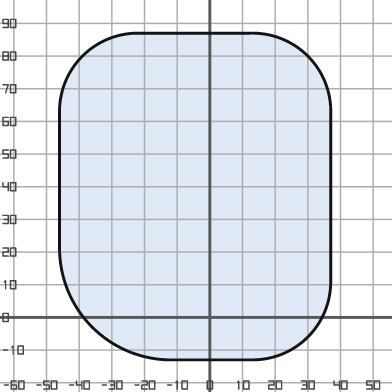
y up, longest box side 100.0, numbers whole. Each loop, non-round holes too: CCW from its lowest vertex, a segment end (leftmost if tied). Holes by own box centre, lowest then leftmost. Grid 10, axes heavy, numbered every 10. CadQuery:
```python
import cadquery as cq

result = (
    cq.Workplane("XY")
    .moveTo(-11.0, -13.0)
    .lineTo(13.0, -13.0)
    .threePointArc((30.0, -6.0), (37.0, 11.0))
    .lineTo(37.0, 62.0)
    .threePointArc((30.0, 80.0), (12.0, 87.0))
    .lineTo(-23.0, 87.0)
    .threePointArc((-39.0, 80.0), (-46.0, 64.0))
    .lineTo(-46.0, 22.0)
    .threePointArc((-36.0, -3.0), (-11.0, -13.0))
    .close()
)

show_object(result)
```